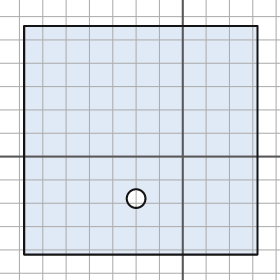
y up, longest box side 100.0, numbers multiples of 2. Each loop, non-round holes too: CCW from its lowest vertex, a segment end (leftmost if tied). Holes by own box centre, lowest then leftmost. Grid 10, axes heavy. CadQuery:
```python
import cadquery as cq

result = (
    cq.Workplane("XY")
    .moveTo(-68.0, -42.0)
    .lineTo(32.0, -42.0)
    .lineTo(32.0, 56.0)
    .lineTo(-68.0, 56.0)
    .close()
    .moveTo(-20.0, -18.0)
    .circle(4.0)
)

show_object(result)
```